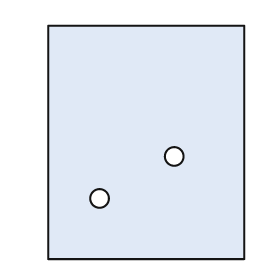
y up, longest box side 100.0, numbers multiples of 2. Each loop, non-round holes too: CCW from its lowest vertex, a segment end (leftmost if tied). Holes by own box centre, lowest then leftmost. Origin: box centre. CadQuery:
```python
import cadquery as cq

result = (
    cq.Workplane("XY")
    .moveTo(-42.0, -50.0)
    .lineTo(42.0, -50.0)
    .lineTo(42.0, 50.0)
    .lineTo(-42.0, 50.0)
    .close()
    .moveTo(-20.0, -24.0)
    .circle(4.0)
    .moveTo(12.0, -6.0)
    .circle(4.0)
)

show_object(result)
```